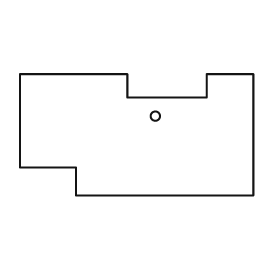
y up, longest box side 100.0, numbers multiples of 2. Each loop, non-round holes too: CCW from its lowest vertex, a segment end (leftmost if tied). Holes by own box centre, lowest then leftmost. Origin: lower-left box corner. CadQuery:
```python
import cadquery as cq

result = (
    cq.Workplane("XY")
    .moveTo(24.0, 0.0)
    .lineTo(100.0, 0.0)
    .lineTo(100.0, 52.0)
    .lineTo(80.0, 52.0)
    .lineTo(80.0, 42.0)
    .lineTo(46.0, 42.0)
    .lineTo(46.0, 52.0)
    .lineTo(0.0, 52.0)
    .lineTo(0.0, 12.0)
    .lineTo(24.0, 12.0)
    .close()
    .moveTo(58.0, 34.0)
    .circle(2.0)
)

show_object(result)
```